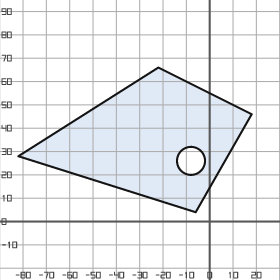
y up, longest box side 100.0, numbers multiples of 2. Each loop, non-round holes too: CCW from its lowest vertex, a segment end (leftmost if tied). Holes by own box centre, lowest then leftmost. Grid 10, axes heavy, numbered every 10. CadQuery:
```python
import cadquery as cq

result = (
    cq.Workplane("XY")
    .moveTo(-6.0, 4.0)
    .lineTo(18.0, 46.0)
    .lineTo(-22.0, 66.0)
    .lineTo(-82.0, 28.0)
    .close()
    .moveTo(-8.0, 26.0)
    .circle(6.0)
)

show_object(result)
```